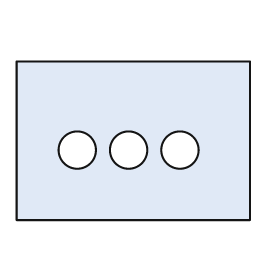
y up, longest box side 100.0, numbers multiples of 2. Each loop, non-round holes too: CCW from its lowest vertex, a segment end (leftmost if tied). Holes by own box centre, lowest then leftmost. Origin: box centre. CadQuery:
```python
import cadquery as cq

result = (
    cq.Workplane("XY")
    .moveTo(-50.0, -34.0)
    .lineTo(50.0, -34.0)
    .lineTo(50.0, 34.0)
    .lineTo(-50.0, 34.0)
    .close()
    .moveTo(-24.0, -4.0)
    .circle(8.0)
    .moveTo(-2.0, -4.0)
    .circle(8.0)
    .moveTo(20.0, -4.0)
    .circle(8.0)
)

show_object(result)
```